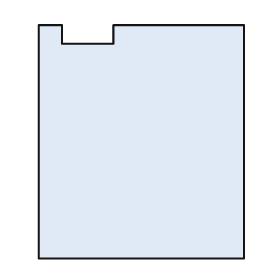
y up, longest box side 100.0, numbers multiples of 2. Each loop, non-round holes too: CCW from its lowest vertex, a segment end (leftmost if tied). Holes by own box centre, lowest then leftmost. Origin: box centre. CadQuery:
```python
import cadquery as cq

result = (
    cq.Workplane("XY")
    .moveTo(-44.0, -50.0)
    .lineTo(44.0, -50.0)
    .lineTo(44.0, 50.0)
    .lineTo(-12.0, 50.0)
    .lineTo(-12.0, 42.0)
    .lineTo(-34.0, 42.0)
    .lineTo(-34.0, 50.0)
    .lineTo(-44.0, 50.0)
    .close()
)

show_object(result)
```